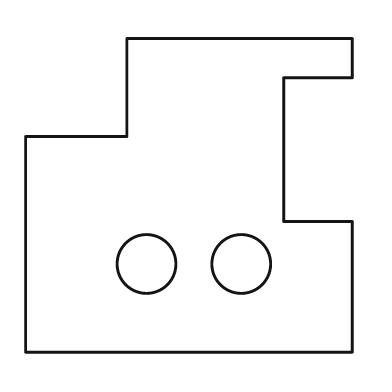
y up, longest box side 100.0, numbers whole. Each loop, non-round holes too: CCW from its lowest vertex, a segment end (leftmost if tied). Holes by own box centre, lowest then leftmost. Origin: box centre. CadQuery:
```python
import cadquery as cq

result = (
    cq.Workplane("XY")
    .moveTo(-50.0, -48.0)
    .lineTo(50.0, -48.0)
    .lineTo(50.0, -8.0)
    .lineTo(29.0, -8.0)
    .lineTo(29.0, 36.0)
    .lineTo(50.0, 36.0)
    .lineTo(50.0, 48.0)
    .lineTo(-19.0, 48.0)
    .lineTo(-19.0, 18.0)
    .lineTo(-50.0, 18.0)
    .close()
    .moveTo(-13.0, -21.0)
    .circle(9.0)
    .moveTo(16.0, -21.0)
    .circle(9.0)
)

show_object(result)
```